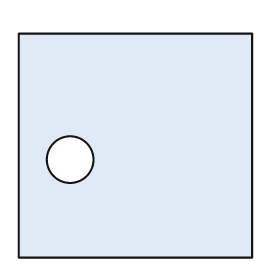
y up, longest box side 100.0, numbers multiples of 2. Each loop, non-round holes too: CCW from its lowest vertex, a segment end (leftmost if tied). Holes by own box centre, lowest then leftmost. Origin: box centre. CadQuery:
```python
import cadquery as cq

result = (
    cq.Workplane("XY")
    .moveTo(-50.0, -48.0)
    .lineTo(50.0, -48.0)
    .lineTo(50.0, 48.0)
    .lineTo(-50.0, 48.0)
    .close()
    .moveTo(-28.0, -6.0)
    .circle(10.0)
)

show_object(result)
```